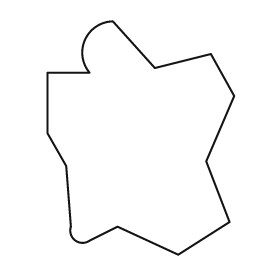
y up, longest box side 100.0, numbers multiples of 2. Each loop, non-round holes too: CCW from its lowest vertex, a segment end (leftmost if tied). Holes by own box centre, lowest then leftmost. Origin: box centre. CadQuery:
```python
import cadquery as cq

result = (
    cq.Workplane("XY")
    .moveTo(16.0, -50.0)
    .lineTo(38.0, -36.0)
    .lineTo(28.0, -10.0)
    .lineTo(40.0, 18.0)
    .lineTo(30.0, 36.0)
    .lineTo(6.0, 30.0)
    .lineTo(-12.0, 50.0)
    .threePointArc((-24.0, 42.0), (-22.0, 28.0))
    .lineTo(-40.0, 28.0)
    .lineTo(-40.0, 2.0)
    .lineTo(-32.0, -12.0)
    .lineTo(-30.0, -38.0)
    .threePointArc((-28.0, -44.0), (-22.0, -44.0))
    .lineTo(-10.0, -38.0)
    .close()
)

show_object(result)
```